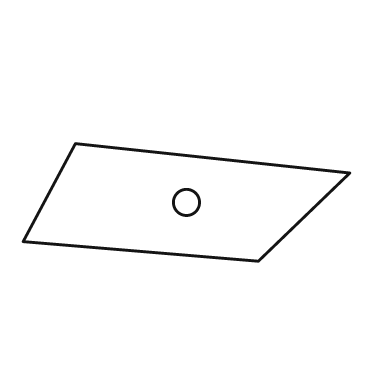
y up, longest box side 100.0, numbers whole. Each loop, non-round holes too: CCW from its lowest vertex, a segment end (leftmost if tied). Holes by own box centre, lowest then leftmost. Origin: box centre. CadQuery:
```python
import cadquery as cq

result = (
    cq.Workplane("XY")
    .moveTo(22.0, -18.0)
    .lineTo(50.0, 9.0)
    .lineTo(-34.0, 18.0)
    .lineTo(-50.0, -12.0)
    .close()
    .moveTo(0.0, 0.0)
    .circle(4.0)
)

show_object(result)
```